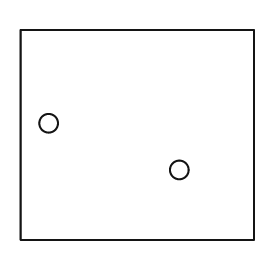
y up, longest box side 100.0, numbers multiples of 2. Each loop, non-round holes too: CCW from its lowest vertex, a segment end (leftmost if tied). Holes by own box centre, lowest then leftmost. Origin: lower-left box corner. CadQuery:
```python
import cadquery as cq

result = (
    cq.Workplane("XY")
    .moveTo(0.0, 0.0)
    .lineTo(100.0, 0.0)
    .lineTo(100.0, 90.0)
    .lineTo(0.0, 90.0)
    .close()
    .moveTo(68.0, 30.0)
    .circle(4.0)
    .moveTo(12.0, 50.0)
    .circle(4.0)
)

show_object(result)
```